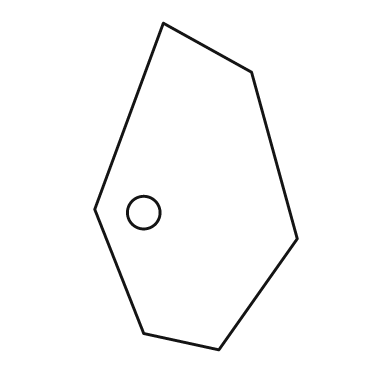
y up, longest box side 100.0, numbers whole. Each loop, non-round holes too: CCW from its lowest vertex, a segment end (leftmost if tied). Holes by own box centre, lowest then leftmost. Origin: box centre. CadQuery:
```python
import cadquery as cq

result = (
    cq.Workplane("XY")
    .moveTo(7.0, -50.0)
    .lineTo(31.0, -16.0)
    .lineTo(17.0, 35.0)
    .lineTo(-10.0, 50.0)
    .lineTo(-31.0, -7.0)
    .lineTo(-16.0, -45.0)
    .close()
    .moveTo(-16.0, -8.0)
    .circle(5.0)
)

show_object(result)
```